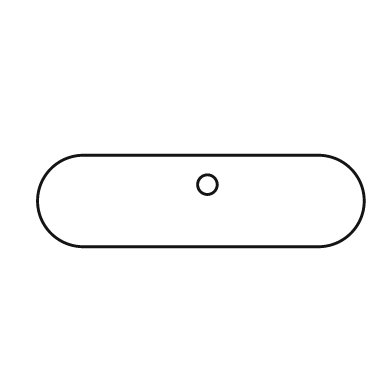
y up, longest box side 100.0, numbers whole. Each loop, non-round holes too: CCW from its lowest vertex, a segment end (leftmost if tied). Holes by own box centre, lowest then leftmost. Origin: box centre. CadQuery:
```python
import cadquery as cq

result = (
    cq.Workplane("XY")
    .moveTo(-36.0, -14.0)
    .lineTo(36.0, -14.0)
    .threePointArc((50.0, 0.0), (36.0, 14.0))
    .lineTo(-36.0, 14.0)
    .threePointArc((-50.0, 0.0), (-36.0, -14.0))
    .close()
    .moveTo(2.0, 5.0)
    .circle(3.0)
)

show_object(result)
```